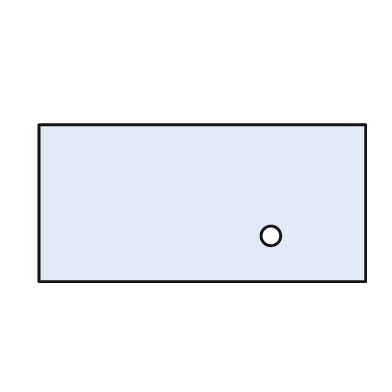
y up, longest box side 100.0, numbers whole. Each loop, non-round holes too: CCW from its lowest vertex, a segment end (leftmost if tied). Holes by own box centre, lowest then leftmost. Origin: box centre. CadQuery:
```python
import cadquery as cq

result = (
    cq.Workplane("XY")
    .moveTo(-50.0, -24.0)
    .lineTo(50.0, -24.0)
    .lineTo(50.0, 24.0)
    .lineTo(-50.0, 24.0)
    .close()
    .moveTo(21.0, -10.0)
    .circle(3.0)
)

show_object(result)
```